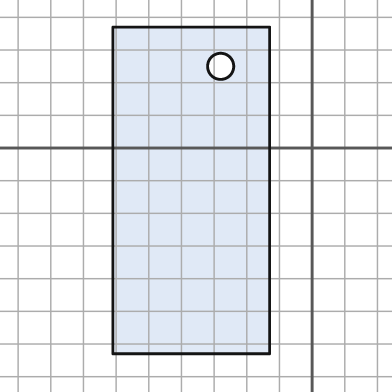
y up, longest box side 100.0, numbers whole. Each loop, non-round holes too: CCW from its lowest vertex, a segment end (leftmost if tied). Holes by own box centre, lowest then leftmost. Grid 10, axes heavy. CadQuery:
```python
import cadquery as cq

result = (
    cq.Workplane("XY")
    .moveTo(-61.0, -63.0)
    .lineTo(-13.0, -63.0)
    .lineTo(-13.0, 37.0)
    .lineTo(-61.0, 37.0)
    .close()
    .moveTo(-28.0, 25.0)
    .circle(4.0)
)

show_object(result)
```